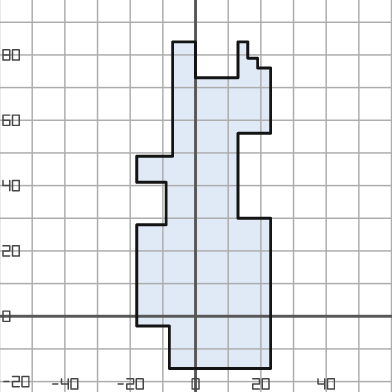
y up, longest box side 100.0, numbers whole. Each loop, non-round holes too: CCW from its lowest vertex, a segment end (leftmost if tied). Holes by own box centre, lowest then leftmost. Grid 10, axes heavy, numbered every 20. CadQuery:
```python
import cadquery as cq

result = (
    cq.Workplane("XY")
    .moveTo(-8.0, -16.0)
    .lineTo(23.0, -16.0)
    .lineTo(23.0, 30.0)
    .lineTo(13.0, 30.0)
    .lineTo(13.0, 56.0)
    .lineTo(23.0, 56.0)
    .lineTo(23.0, 76.0)
    .lineTo(19.0, 76.0)
    .lineTo(19.0, 79.0)
    .lineTo(16.0, 79.0)
    .lineTo(16.0, 84.0)
    .lineTo(13.0, 84.0)
    .lineTo(13.0, 73.0)
    .lineTo(0.0, 73.0)
    .lineTo(0.0, 84.0)
    .lineTo(-7.0, 84.0)
    .lineTo(-7.0, 49.0)
    .lineTo(-18.0, 49.0)
    .lineTo(-18.0, 41.0)
    .lineTo(-9.0, 41.0)
    .lineTo(-9.0, 28.0)
    .lineTo(-18.0, 28.0)
    .lineTo(-18.0, -3.0)
    .lineTo(-8.0, -3.0)
    .close()
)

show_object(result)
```